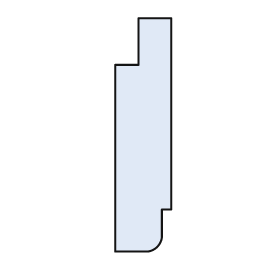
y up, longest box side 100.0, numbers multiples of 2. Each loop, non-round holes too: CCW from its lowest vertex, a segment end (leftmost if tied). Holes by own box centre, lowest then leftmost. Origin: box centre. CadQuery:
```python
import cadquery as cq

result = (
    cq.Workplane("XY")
    .moveTo(-12.0, -50.0)
    .lineTo(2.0, -50.0)
    .threePointArc((6.0, -48.0), (8.0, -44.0))
    .lineTo(8.0, -32.0)
    .lineTo(12.0, -32.0)
    .lineTo(12.0, 50.0)
    .lineTo(-2.0, 50.0)
    .lineTo(-2.0, 30.0)
    .lineTo(-12.0, 30.0)
    .close()
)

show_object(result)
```